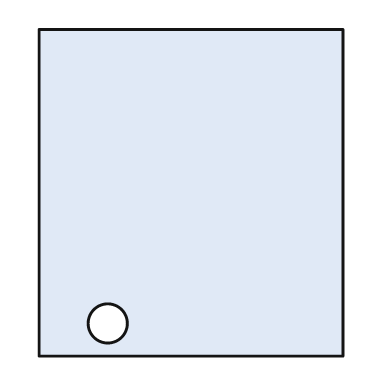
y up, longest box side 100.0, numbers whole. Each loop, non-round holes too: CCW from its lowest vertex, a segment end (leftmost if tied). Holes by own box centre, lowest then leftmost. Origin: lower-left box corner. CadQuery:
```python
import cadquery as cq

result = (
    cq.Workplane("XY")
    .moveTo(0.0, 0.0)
    .lineTo(93.0, 0.0)
    .lineTo(93.0, 100.0)
    .lineTo(0.0, 100.0)
    .close()
    .moveTo(21.0, 10.0)
    .circle(6.0)
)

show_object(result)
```